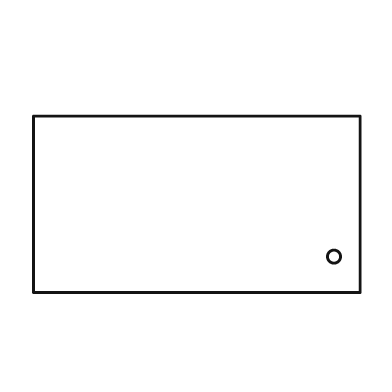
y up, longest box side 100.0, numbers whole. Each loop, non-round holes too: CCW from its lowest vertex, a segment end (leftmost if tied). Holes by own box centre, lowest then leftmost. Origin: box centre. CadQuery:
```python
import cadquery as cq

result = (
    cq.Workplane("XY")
    .moveTo(-50.0, -27.0)
    .lineTo(50.0, -27.0)
    .lineTo(50.0, 27.0)
    .lineTo(-50.0, 27.0)
    .close()
    .moveTo(42.0, -16.0)
    .circle(2.0)
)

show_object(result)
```